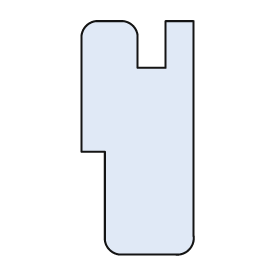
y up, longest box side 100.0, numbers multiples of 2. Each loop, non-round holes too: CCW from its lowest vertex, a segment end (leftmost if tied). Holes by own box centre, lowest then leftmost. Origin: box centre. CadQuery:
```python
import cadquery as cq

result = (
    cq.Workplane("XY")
    .moveTo(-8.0, -50.0)
    .lineTo(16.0, -50.0)
    .threePointArc((22.0, -48.0), (24.0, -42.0))
    .lineTo(24.0, 50.0)
    .lineTo(12.0, 50.0)
    .lineTo(12.0, 30.0)
    .lineTo(0.0, 30.0)
    .lineTo(0.0, 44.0)
    .threePointArc((-2.0, 48.0), (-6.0, 50.0))
    .lineTo(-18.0, 50.0)
    .threePointArc((-22.0, 48.0), (-24.0, 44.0))
    .lineTo(-24.0, -6.0)
    .lineTo(-14.0, -6.0)
    .lineTo(-14.0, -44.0)
    .threePointArc((-12.0, -48.0), (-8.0, -50.0))
    .close()
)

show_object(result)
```